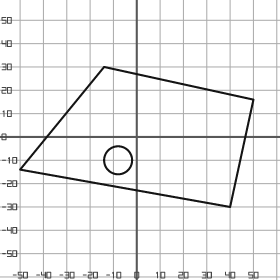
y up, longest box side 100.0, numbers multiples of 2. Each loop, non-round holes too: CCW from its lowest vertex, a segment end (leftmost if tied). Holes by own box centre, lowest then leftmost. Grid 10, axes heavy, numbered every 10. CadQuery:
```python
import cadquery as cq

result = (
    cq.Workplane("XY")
    .moveTo(40.0, -30.0)
    .lineTo(50.0, 16.0)
    .lineTo(-14.0, 30.0)
    .lineTo(-50.0, -14.0)
    .close()
    .moveTo(-8.0, -10.0)
    .circle(6.0)
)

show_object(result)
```